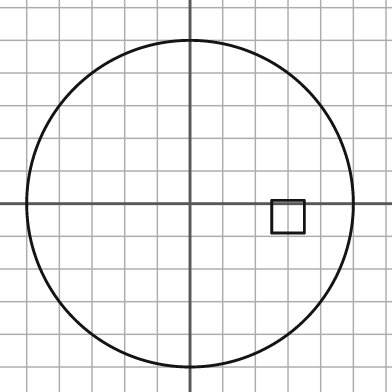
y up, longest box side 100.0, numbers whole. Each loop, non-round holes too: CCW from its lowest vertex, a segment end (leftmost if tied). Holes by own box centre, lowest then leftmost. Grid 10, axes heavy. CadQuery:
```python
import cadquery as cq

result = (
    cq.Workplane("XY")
    .moveTo(0.0, 0.0)
    .circle(50.0)
    .moveTo(25.0, -9.0)
    .lineTo(35.0, -9.0)
    .lineTo(35.0, 1.0)
    .lineTo(25.0, 1.0)
    .close()
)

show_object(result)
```